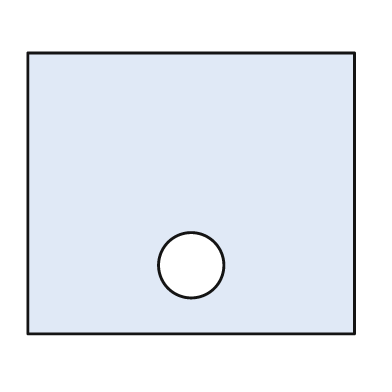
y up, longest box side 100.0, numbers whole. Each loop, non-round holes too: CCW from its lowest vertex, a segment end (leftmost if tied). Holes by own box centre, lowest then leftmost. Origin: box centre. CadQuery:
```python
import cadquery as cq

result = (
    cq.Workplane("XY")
    .moveTo(-50.0, -43.0)
    .lineTo(50.0, -43.0)
    .lineTo(50.0, 43.0)
    .lineTo(-50.0, 43.0)
    .close()
    .moveTo(0.0, -22.0)
    .circle(10.0)
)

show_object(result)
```